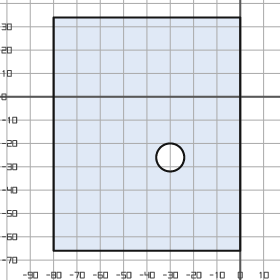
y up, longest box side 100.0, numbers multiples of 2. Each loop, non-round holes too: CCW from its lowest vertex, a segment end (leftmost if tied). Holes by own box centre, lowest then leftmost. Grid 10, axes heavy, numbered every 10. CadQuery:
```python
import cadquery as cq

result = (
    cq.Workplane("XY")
    .moveTo(-80.0, -66.0)
    .lineTo(0.0, -66.0)
    .lineTo(0.0, 34.0)
    .lineTo(-80.0, 34.0)
    .close()
    .moveTo(-30.0, -26.0)
    .circle(6.0)
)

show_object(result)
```